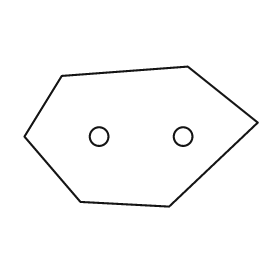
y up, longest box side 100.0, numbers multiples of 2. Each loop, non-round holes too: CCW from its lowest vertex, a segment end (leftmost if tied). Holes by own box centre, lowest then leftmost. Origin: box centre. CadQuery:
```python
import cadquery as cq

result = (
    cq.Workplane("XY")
    .moveTo(12.0, -30.0)
    .lineTo(50.0, 6.0)
    .lineTo(20.0, 30.0)
    .lineTo(-34.0, 26.0)
    .lineTo(-50.0, 0.0)
    .lineTo(-26.0, -28.0)
    .close()
    .moveTo(-18.0, 0.0)
    .circle(4.0)
    .moveTo(18.0, 0.0)
    .circle(4.0)
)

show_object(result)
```